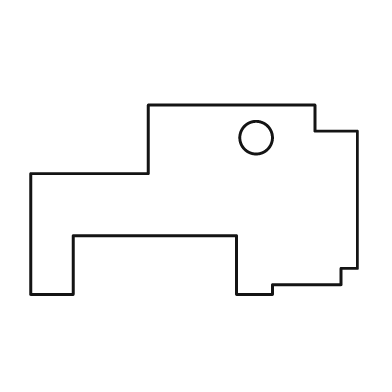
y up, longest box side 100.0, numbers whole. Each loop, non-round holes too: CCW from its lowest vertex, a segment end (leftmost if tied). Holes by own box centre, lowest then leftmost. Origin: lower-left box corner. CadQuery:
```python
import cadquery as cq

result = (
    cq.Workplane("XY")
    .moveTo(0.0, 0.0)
    .lineTo(13.0, 0.0)
    .lineTo(13.0, 18.0)
    .lineTo(63.0, 18.0)
    .lineTo(63.0, 0.0)
    .lineTo(74.0, 0.0)
    .lineTo(74.0, 3.0)
    .lineTo(95.0, 3.0)
    .lineTo(95.0, 8.0)
    .lineTo(100.0, 8.0)
    .lineTo(100.0, 50.0)
    .lineTo(87.0, 50.0)
    .lineTo(87.0, 58.0)
    .lineTo(36.0, 58.0)
    .lineTo(36.0, 37.0)
    .lineTo(0.0, 37.0)
    .close()
    .moveTo(69.0, 48.0)
    .circle(5.0)
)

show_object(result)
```